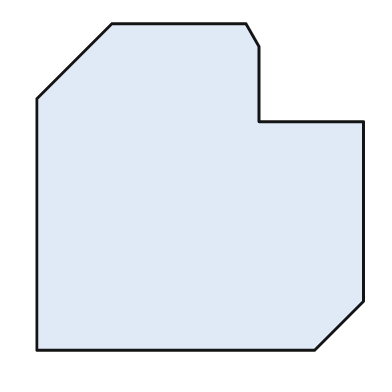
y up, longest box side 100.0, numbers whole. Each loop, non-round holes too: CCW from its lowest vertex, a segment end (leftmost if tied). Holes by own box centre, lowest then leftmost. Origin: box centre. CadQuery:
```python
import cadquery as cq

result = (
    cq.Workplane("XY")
    .moveTo(-50.0, -50.0)
    .lineTo(35.0, -50.0)
    .lineTo(50.0, -35.0)
    .lineTo(50.0, 20.0)
    .lineTo(18.0, 20.0)
    .lineTo(18.0, 43.0)
    .lineTo(14.0, 50.0)
    .lineTo(-27.0, 50.0)
    .lineTo(-50.0, 27.0)
    .close()
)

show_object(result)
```